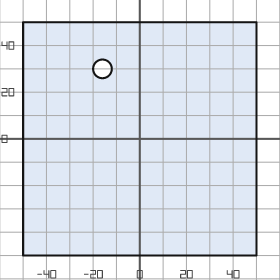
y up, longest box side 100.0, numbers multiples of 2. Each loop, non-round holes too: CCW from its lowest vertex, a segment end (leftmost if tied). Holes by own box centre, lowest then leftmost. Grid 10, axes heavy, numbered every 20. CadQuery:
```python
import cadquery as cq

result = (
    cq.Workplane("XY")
    .moveTo(-50.0, -50.0)
    .lineTo(50.0, -50.0)
    .lineTo(50.0, 50.0)
    .lineTo(-50.0, 50.0)
    .close()
    .moveTo(-16.0, 30.0)
    .circle(4.0)
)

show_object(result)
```